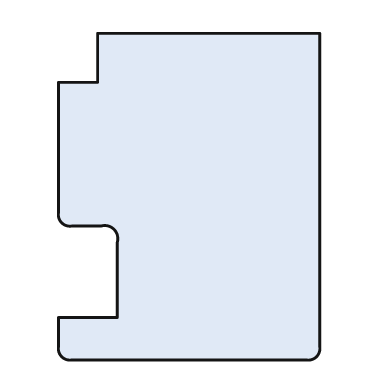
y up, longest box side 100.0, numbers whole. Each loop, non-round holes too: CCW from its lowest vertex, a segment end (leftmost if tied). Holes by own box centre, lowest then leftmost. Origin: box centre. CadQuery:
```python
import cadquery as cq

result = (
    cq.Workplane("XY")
    .moveTo(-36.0, -50.0)
    .lineTo(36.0, -50.0)
    .threePointArc((39.0, -49.0), (40.0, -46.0))
    .lineTo(40.0, 50.0)
    .lineTo(-28.0, 50.0)
    .lineTo(-28.0, 35.0)
    .lineTo(-40.0, 35.0)
    .lineTo(-40.0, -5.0)
    .threePointArc((-39.0, -8.0), (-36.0, -9.0))
    .lineTo(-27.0, -9.0)
    .threePointArc((-23.0, -10.0), (-22.0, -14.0))
    .lineTo(-22.0, -37.0)
    .lineTo(-40.0, -37.0)
    .lineTo(-40.0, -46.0)
    .threePointArc((-39.0, -49.0), (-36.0, -50.0))
    .close()
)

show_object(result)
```